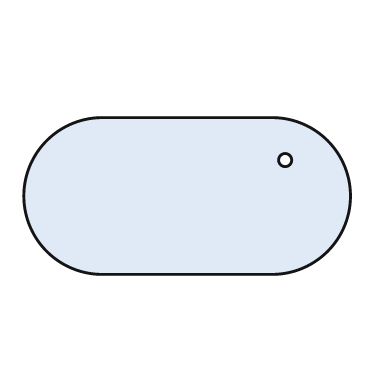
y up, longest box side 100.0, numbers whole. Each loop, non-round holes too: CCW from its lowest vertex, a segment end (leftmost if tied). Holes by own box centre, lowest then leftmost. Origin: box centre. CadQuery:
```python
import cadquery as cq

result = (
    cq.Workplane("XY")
    .moveTo(-26.0, -24.0)
    .lineTo(26.0, -24.0)
    .threePointArc((50.0, 0.0), (26.0, 24.0))
    .lineTo(-26.0, 24.0)
    .threePointArc((-50.0, 0.0), (-26.0, -24.0))
    .close()
    .moveTo(30.0, 11.0)
    .circle(2.0)
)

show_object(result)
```